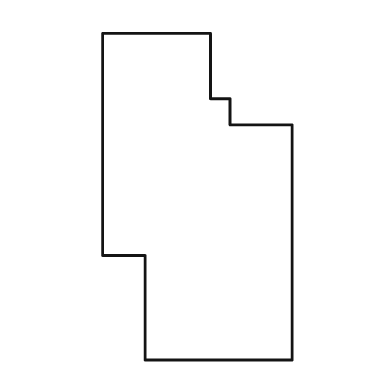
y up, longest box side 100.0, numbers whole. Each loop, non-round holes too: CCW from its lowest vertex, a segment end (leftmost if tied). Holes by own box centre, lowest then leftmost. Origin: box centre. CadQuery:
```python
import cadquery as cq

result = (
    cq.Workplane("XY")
    .moveTo(-16.0, -50.0)
    .lineTo(29.0, -50.0)
    .lineTo(29.0, 22.0)
    .lineTo(10.0, 22.0)
    .lineTo(10.0, 30.0)
    .lineTo(4.0, 30.0)
    .lineTo(4.0, 50.0)
    .lineTo(-29.0, 50.0)
    .lineTo(-29.0, -18.0)
    .lineTo(-16.0, -18.0)
    .close()
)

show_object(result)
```